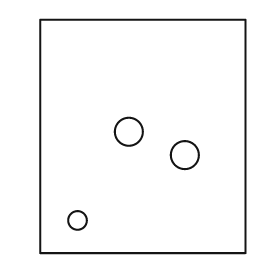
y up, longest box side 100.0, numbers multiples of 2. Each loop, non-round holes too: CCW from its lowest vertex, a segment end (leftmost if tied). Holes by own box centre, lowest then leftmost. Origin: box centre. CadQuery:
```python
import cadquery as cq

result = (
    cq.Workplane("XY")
    .moveTo(-44.0, -50.0)
    .lineTo(44.0, -50.0)
    .lineTo(44.0, 50.0)
    .lineTo(-44.0, 50.0)
    .close()
    .moveTo(-28.0, -36.0)
    .circle(4.0)
    .moveTo(18.0, -8.0)
    .circle(6.0)
    .moveTo(-6.0, 2.0)
    .circle(6.0)
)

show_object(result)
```